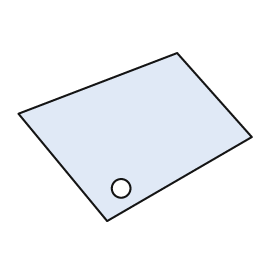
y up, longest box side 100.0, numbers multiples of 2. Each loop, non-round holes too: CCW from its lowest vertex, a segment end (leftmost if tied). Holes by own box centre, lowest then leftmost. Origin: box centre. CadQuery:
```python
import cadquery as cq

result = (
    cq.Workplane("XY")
    .moveTo(-12.0, -36.0)
    .lineTo(50.0, 0.0)
    .lineTo(18.0, 36.0)
    .lineTo(-50.0, 10.0)
    .close()
    .moveTo(-6.0, -22.0)
    .circle(4.0)
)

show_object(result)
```